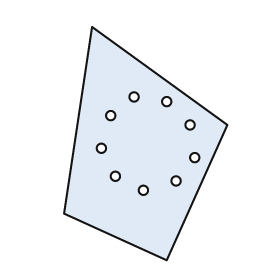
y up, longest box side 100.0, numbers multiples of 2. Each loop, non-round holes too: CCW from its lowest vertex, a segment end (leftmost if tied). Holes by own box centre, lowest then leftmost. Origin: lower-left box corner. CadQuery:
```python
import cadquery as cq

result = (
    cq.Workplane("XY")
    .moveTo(44.0, 0.0)
    .lineTo(70.0, 58.0)
    .lineTo(12.0, 100.0)
    .lineTo(0.0, 20.0)
    .close()
    .moveTo(34.0, 30.0)
    .circle(2.0)
    .moveTo(48.0, 34.0)
    .circle(2.0)
    .moveTo(22.0, 36.0)
    .circle(2.0)
    .moveTo(56.0, 44.0)
    .circle(2.0)
    .moveTo(16.0, 48.0)
    .circle(2.0)
    .moveTo(54.0, 58.0)
    .circle(2.0)
    .moveTo(20.0, 62.0)
    .circle(2.0)
    .moveTo(44.0, 68.0)
    .circle(2.0)
    .moveTo(30.0, 70.0)
    .circle(2.0)
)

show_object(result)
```